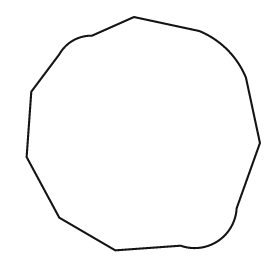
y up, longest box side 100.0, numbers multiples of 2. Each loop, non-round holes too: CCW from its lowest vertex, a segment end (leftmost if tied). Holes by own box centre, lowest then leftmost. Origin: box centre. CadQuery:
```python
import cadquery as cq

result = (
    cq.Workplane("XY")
    .moveTo(-12.0, -50.0)
    .lineTo(16.0, -48.0)
    .threePointArc((32.0, -46.0), (40.0, -32.0))
    .lineTo(50.0, -4.0)
    .lineTo(44.0, 24.0)
    .threePointArc((36.0, 36.0), (24.0, 44.0))
    .lineTo(-4.0, 50.0)
    .lineTo(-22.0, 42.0)
    .threePointArc((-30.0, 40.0), (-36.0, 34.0))
    .lineTo(-48.0, 18.0)
    .lineTo(-50.0, -10.0)
    .lineTo(-36.0, -36.0)
    .close()
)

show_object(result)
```